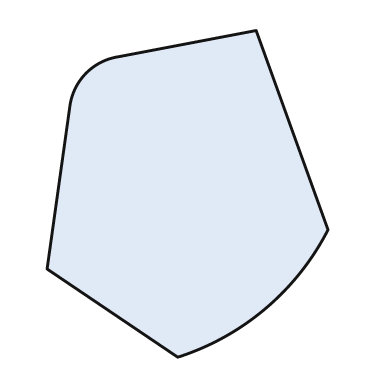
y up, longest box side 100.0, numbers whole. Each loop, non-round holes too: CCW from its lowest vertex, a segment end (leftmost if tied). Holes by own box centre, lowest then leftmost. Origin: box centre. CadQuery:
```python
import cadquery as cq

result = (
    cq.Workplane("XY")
    .moveTo(-3.0, -50.0)
    .threePointArc((24.0, -35.0), (43.0, -11.0))
    .lineTo(21.0, 50.0)
    .lineTo(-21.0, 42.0)
    .threePointArc((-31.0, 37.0), (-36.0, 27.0))
    .lineTo(-43.0, -23.0)
    .close()
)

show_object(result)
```